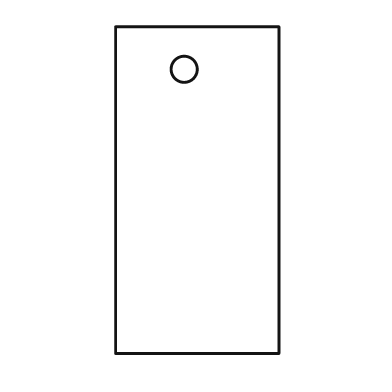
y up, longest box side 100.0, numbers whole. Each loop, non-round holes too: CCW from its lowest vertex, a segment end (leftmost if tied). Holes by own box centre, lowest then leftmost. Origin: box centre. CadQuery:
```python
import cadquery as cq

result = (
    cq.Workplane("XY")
    .moveTo(-25.0, -50.0)
    .lineTo(25.0, -50.0)
    .lineTo(25.0, 50.0)
    .lineTo(-25.0, 50.0)
    .close()
    .moveTo(-4.0, 37.0)
    .circle(4.0)
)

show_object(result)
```